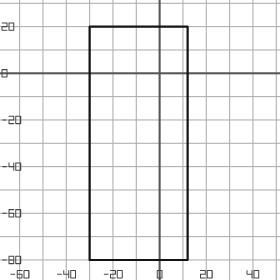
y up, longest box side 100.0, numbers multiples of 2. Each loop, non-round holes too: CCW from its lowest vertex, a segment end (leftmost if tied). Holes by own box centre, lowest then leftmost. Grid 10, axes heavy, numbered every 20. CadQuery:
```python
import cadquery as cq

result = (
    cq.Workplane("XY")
    .moveTo(-30.0, -80.0)
    .lineTo(12.0, -80.0)
    .lineTo(12.0, 20.0)
    .lineTo(-30.0, 20.0)
    .close()
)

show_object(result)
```